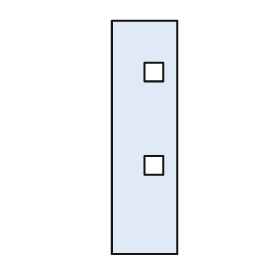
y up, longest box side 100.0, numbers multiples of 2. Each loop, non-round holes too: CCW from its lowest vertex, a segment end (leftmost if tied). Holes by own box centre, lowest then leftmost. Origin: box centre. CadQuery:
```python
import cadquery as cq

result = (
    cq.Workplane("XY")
    .moveTo(-14.0, -50.0)
    .lineTo(14.0, -50.0)
    .lineTo(14.0, 50.0)
    .lineTo(-14.0, 50.0)
    .close()
    .moveTo(0.0, -16.0)
    .lineTo(8.0, -16.0)
    .lineTo(8.0, -8.0)
    .lineTo(0.0, -8.0)
    .close()
    .moveTo(0.0, 24.0)
    .lineTo(8.0, 24.0)
    .lineTo(8.0, 32.0)
    .lineTo(0.0, 32.0)
    .close()
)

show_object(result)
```